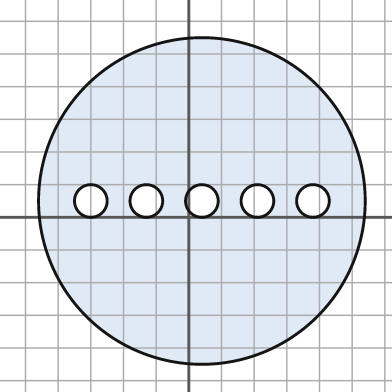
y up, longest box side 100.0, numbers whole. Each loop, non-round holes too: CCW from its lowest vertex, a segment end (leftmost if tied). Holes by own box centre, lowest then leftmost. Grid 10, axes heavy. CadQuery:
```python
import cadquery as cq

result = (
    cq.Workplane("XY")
    .moveTo(4.0, 5.0)
    .circle(50.0)
    .moveTo(-30.0, 5.0)
    .circle(5.0)
    .moveTo(-13.0, 5.0)
    .circle(5.0)
    .moveTo(4.0, 5.0)
    .circle(5.0)
    .moveTo(21.0, 5.0)
    .circle(5.0)
    .moveTo(38.0, 5.0)
    .circle(5.0)
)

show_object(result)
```